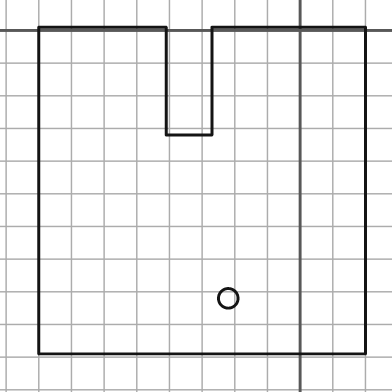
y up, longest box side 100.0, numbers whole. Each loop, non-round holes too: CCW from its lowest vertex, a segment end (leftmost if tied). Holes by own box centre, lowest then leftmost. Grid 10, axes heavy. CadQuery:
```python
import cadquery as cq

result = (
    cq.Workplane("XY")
    .moveTo(-80.0, -99.0)
    .lineTo(20.0, -99.0)
    .lineTo(20.0, 1.0)
    .lineTo(-27.0, 1.0)
    .lineTo(-27.0, -32.0)
    .lineTo(-41.0, -32.0)
    .lineTo(-41.0, 1.0)
    .lineTo(-80.0, 1.0)
    .close()
    .moveTo(-22.0, -82.0)
    .circle(3.0)
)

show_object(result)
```